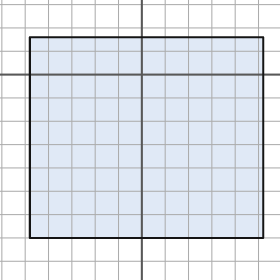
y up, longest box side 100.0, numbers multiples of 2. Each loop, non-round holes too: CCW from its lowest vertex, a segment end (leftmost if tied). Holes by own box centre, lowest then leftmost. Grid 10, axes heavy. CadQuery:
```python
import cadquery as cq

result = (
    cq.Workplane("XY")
    .moveTo(-48.0, -70.0)
    .lineTo(52.0, -70.0)
    .lineTo(52.0, 16.0)
    .lineTo(-48.0, 16.0)
    .close()
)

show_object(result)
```